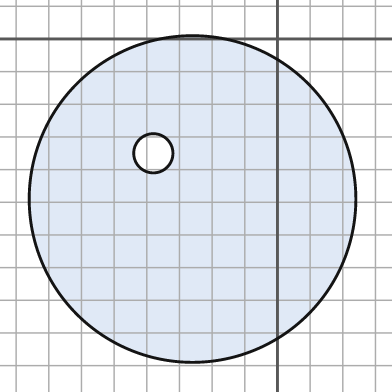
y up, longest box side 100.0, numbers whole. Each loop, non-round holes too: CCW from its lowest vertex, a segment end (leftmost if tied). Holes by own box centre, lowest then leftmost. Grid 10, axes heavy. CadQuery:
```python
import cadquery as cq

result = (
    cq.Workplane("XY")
    .moveTo(-26.0, -49.0)
    .circle(50.0)
    .moveTo(-38.0, -35.0)
    .circle(6.0)
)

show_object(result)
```